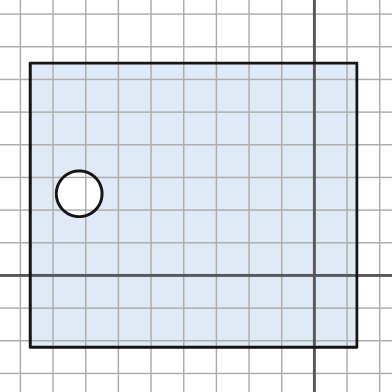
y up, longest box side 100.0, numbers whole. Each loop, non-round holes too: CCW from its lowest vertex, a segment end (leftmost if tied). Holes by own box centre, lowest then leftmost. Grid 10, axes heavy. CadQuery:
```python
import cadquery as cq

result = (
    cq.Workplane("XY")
    .moveTo(-87.0, -22.0)
    .lineTo(13.0, -22.0)
    .lineTo(13.0, 65.0)
    .lineTo(-87.0, 65.0)
    .close()
    .moveTo(-72.0, 25.0)
    .circle(7.0)
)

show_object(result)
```